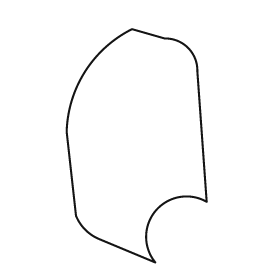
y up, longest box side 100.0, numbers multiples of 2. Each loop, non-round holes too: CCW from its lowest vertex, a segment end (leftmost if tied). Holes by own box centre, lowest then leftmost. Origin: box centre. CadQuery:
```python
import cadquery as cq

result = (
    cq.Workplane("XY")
    .moveTo(8.0, -50.0)
    .threePointArc((8.0, -28.0), (30.0, -24.0))
    .lineTo(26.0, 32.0)
    .threePointArc((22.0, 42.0), (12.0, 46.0))
    .lineTo(-2.0, 50.0)
    .threePointArc((-22.0, 32.0), (-30.0, 6.0))
    .lineTo(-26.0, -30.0)
    .threePointArc((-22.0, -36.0), (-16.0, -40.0))
    .close()
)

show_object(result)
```